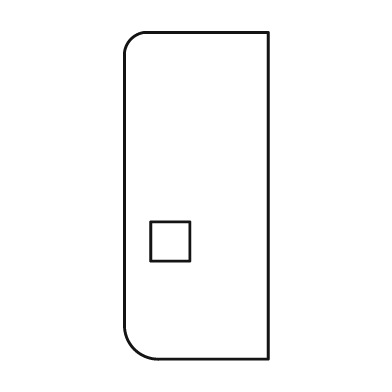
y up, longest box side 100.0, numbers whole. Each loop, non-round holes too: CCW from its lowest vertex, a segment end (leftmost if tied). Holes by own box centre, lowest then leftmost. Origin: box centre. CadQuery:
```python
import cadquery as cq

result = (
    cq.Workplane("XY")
    .moveTo(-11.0, -50.0)
    .lineTo(22.0, -50.0)
    .lineTo(22.0, 50.0)
    .lineTo(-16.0, 50.0)
    .threePointArc((-20.0, 48.0), (-22.0, 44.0))
    .lineTo(-22.0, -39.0)
    .threePointArc((-19.0, -47.0), (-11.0, -50.0))
    .close()
    .moveTo(-14.0, -20.0)
    .lineTo(-2.0, -20.0)
    .lineTo(-2.0, -8.0)
    .lineTo(-14.0, -8.0)
    .close()
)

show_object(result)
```